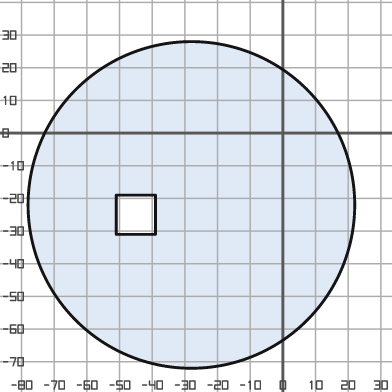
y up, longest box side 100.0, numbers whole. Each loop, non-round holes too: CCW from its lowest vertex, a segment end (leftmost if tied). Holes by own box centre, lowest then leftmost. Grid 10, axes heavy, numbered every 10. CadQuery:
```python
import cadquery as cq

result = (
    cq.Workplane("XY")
    .moveTo(-28.0, -22.0)
    .circle(50.0)
    .moveTo(-51.0, -31.0)
    .lineTo(-39.0, -31.0)
    .lineTo(-39.0, -19.0)
    .lineTo(-51.0, -19.0)
    .close()
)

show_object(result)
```